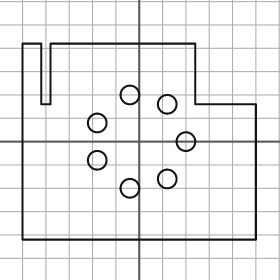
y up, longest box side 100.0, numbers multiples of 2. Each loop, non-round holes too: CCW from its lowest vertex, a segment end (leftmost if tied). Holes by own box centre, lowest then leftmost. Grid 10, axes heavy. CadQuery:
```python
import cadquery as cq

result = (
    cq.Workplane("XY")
    .moveTo(-50.0, -42.0)
    .lineTo(50.0, -42.0)
    .lineTo(50.0, 16.0)
    .lineTo(24.0, 16.0)
    .lineTo(24.0, 42.0)
    .lineTo(-38.0, 42.0)
    .lineTo(-38.0, 16.0)
    .lineTo(-42.0, 16.0)
    .lineTo(-42.0, 42.0)
    .lineTo(-50.0, 42.0)
    .close()
    .moveTo(-4.0, -20.0)
    .circle(4.0)
    .moveTo(12.0, -16.0)
    .circle(4.0)
    .moveTo(-18.0, -8.0)
    .circle(4.0)
    .moveTo(20.0, 0.0)
    .circle(4.0)
    .moveTo(-18.0, 8.0)
    .circle(4.0)
    .moveTo(12.0, 16.0)
    .circle(4.0)
    .moveTo(-4.0, 20.0)
    .circle(4.0)
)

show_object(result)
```